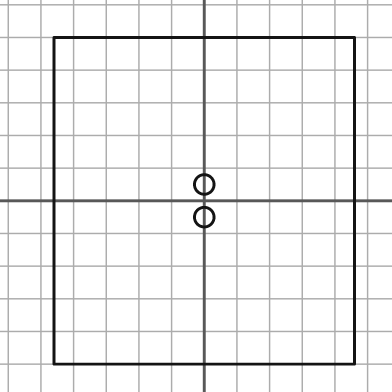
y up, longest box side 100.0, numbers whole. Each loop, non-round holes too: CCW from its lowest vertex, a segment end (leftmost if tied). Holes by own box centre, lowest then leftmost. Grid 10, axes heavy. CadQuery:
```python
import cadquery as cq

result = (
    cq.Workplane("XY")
    .moveTo(-46.0, -50.0)
    .lineTo(46.0, -50.0)
    .lineTo(46.0, 50.0)
    .lineTo(-46.0, 50.0)
    .close()
    .moveTo(0.0, -5.0)
    .circle(3.0)
    .moveTo(0.0, 5.0)
    .circle(3.0)
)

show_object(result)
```